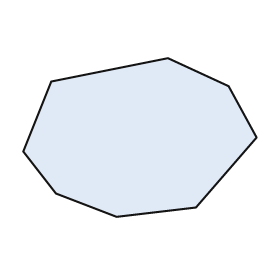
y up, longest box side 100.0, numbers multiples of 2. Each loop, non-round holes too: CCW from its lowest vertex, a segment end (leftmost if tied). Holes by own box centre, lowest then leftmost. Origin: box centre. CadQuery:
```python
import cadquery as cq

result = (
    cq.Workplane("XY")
    .moveTo(-10.0, -34.0)
    .lineTo(24.0, -30.0)
    .lineTo(50.0, 0.0)
    .lineTo(38.0, 22.0)
    .lineTo(12.0, 34.0)
    .lineTo(-38.0, 24.0)
    .lineTo(-50.0, -6.0)
    .lineTo(-36.0, -24.0)
    .close()
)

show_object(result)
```